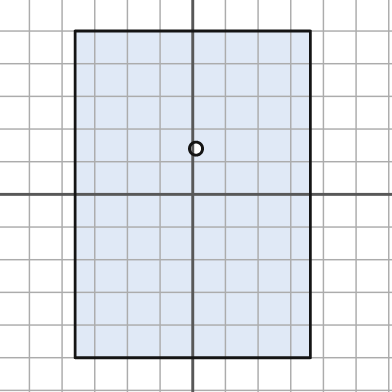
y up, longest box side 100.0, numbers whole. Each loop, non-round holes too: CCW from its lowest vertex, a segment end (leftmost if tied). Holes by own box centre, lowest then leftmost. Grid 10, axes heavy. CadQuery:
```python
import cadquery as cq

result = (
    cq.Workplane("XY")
    .moveTo(-36.0, -50.0)
    .lineTo(36.0, -50.0)
    .lineTo(36.0, 50.0)
    .lineTo(-36.0, 50.0)
    .close()
    .moveTo(1.0, 14.0)
    .circle(2.0)
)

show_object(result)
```